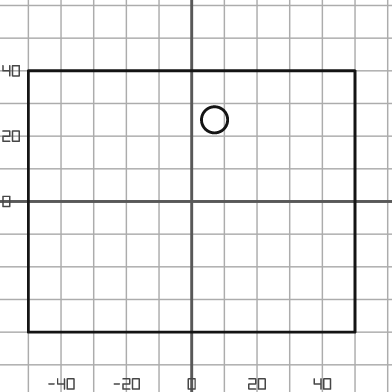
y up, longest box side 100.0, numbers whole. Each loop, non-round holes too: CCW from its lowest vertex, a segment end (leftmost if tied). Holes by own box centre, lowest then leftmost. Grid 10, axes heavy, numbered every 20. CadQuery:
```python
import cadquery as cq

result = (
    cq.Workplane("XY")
    .moveTo(-50.0, -40.0)
    .lineTo(50.0, -40.0)
    .lineTo(50.0, 40.0)
    .lineTo(-50.0, 40.0)
    .close()
    .moveTo(7.0, 25.0)
    .circle(4.0)
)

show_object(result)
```